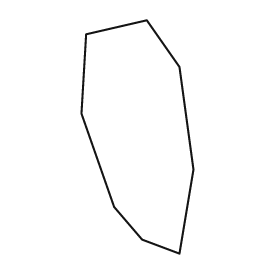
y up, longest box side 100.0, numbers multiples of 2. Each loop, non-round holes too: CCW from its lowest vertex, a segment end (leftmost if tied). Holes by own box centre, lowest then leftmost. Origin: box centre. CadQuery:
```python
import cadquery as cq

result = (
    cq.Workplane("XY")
    .moveTo(18.0, -50.0)
    .lineTo(24.0, -14.0)
    .lineTo(18.0, 30.0)
    .lineTo(4.0, 50.0)
    .lineTo(-22.0, 44.0)
    .lineTo(-24.0, 10.0)
    .lineTo(-10.0, -30.0)
    .lineTo(2.0, -44.0)
    .close()
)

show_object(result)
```